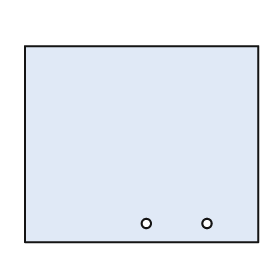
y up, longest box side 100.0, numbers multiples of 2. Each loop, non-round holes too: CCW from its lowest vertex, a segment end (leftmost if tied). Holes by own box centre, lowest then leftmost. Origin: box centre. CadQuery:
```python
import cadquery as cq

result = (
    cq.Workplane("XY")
    .moveTo(-50.0, -42.0)
    .lineTo(50.0, -42.0)
    .lineTo(50.0, 42.0)
    .lineTo(-50.0, 42.0)
    .close()
    .moveTo(2.0, -34.0)
    .circle(2.0)
    .moveTo(28.0, -34.0)
    .circle(2.0)
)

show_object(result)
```